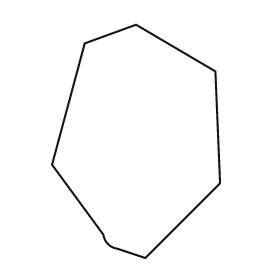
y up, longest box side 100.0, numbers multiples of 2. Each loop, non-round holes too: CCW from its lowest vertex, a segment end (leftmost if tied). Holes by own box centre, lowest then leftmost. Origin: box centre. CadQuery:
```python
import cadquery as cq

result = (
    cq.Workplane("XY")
    .moveTo(4.0, -50.0)
    .lineTo(36.0, -18.0)
    .lineTo(34.0, 30.0)
    .lineTo(0.0, 50.0)
    .lineTo(-22.0, 42.0)
    .lineTo(-36.0, -10.0)
    .lineTo(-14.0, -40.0)
    .threePointArc((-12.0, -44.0), (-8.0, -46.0))
    .close()
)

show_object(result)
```